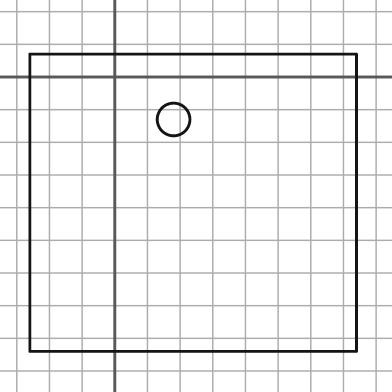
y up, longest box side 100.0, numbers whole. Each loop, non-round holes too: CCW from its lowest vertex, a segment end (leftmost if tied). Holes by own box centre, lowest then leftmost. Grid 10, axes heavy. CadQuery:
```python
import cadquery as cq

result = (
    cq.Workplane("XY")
    .moveTo(-26.0, -84.0)
    .lineTo(74.0, -84.0)
    .lineTo(74.0, 7.0)
    .lineTo(-26.0, 7.0)
    .close()
    .moveTo(18.0, -13.0)
    .circle(5.0)
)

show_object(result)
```